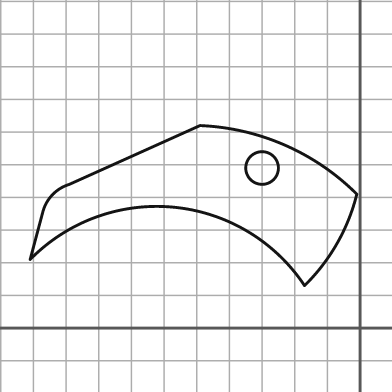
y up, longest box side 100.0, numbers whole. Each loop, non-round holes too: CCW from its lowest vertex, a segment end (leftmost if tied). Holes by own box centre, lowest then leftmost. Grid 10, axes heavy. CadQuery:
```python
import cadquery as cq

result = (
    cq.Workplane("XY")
    .moveTo(-17.0, 13.0)
    .threePointArc((-7.0, 26.0), (-1.0, 41.0))
    .threePointArc((-23.0, 56.0), (-49.0, 62.0))
    .lineTo(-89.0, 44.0)
    .threePointArc((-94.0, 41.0), (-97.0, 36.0))
    .lineTo(-101.0, 21.0)
    .threePointArc((-57.0, 37.0), (-17.0, 13.0))
    .close()
    .moveTo(-30.0, 49.0)
    .circle(5.0)
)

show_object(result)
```